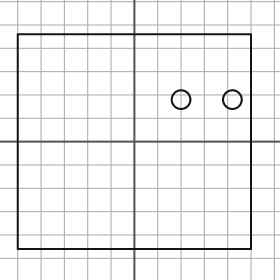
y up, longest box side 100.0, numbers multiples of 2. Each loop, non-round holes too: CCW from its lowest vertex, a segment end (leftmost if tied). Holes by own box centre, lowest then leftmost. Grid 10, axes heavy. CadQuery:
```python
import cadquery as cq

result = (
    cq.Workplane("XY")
    .moveTo(-50.0, -46.0)
    .lineTo(50.0, -46.0)
    .lineTo(50.0, 46.0)
    .lineTo(-50.0, 46.0)
    .close()
    .moveTo(20.0, 18.0)
    .circle(4.0)
    .moveTo(42.0, 18.0)
    .circle(4.0)
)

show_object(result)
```